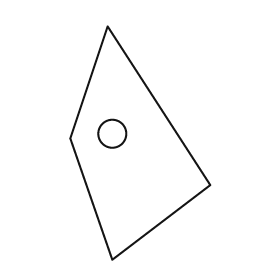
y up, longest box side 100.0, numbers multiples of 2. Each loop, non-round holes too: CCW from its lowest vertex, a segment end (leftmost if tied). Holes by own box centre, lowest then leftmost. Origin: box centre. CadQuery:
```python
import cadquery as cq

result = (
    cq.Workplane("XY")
    .moveTo(-12.0, -50.0)
    .lineTo(30.0, -18.0)
    .lineTo(-14.0, 50.0)
    .lineTo(-30.0, 2.0)
    .close()
    .moveTo(-12.0, 4.0)
    .circle(6.0)
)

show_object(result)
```